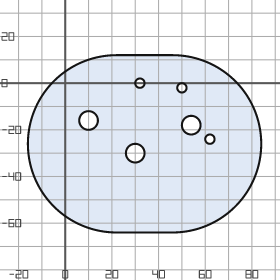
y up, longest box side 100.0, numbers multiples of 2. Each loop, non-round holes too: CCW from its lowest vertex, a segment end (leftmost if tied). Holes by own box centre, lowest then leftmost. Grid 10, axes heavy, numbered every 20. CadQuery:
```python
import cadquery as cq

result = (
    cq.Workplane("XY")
    .moveTo(22.0, -64.0)
    .lineTo(46.0, -64.0)
    .threePointArc((84.0, -26.0), (46.0, 12.0))
    .lineTo(22.0, 12.0)
    .threePointArc((-16.0, -26.0), (22.0, -64.0))
    .close()
    .moveTo(30.0, -30.0)
    .circle(4.0)
    .moveTo(62.0, -24.0)
    .circle(2.0)
    .moveTo(54.0, -18.0)
    .circle(4.0)
    .moveTo(10.0, -16.0)
    .circle(4.0)
    .moveTo(50.0, -2.0)
    .circle(2.0)
    .moveTo(32.0, 0.0)
    .circle(2.0)
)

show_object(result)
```